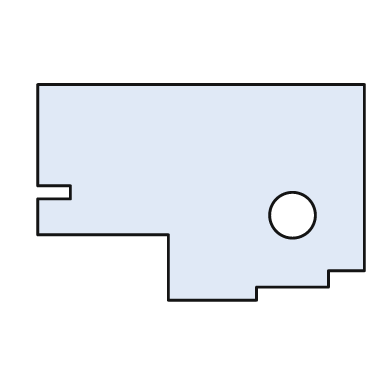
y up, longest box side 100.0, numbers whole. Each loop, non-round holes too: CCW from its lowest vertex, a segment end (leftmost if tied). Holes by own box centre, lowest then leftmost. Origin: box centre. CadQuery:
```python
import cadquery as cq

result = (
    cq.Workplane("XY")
    .moveTo(-10.0, -33.0)
    .lineTo(17.0, -33.0)
    .lineTo(17.0, -29.0)
    .lineTo(39.0, -29.0)
    .lineTo(39.0, -24.0)
    .lineTo(50.0, -24.0)
    .lineTo(50.0, 33.0)
    .lineTo(-50.0, 33.0)
    .lineTo(-50.0, 2.0)
    .lineTo(-40.0, 2.0)
    .lineTo(-40.0, -2.0)
    .lineTo(-50.0, -2.0)
    .lineTo(-50.0, -13.0)
    .lineTo(-10.0, -13.0)
    .close()
    .moveTo(28.0, -7.0)
    .circle(7.0)
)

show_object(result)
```